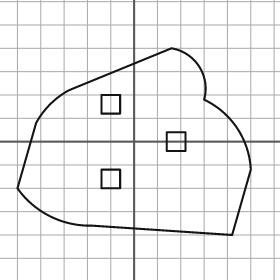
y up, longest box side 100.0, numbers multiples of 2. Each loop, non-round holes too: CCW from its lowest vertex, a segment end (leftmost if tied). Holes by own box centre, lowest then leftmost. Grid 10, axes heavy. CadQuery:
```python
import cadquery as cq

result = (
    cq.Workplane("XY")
    .moveTo(42.0, -40.0)
    .lineTo(50.0, -12.0)
    .threePointArc((44.0, 6.0), (30.0, 18.0))
    .threePointArc((28.0, 32.0), (16.0, 40.0))
    .lineTo(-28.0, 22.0)
    .threePointArc((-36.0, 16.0), (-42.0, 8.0))
    .lineTo(-50.0, -20.0)
    .threePointArc((-36.0, -32.0), (-18.0, -36.0))
    .close()
    .moveTo(-14.0, -20.0)
    .lineTo(-6.0, -20.0)
    .lineTo(-6.0, -12.0)
    .lineTo(-14.0, -12.0)
    .close()
    .moveTo(14.0, -4.0)
    .lineTo(22.0, -4.0)
    .lineTo(22.0, 4.0)
    .lineTo(14.0, 4.0)
    .close()
    .moveTo(-14.0, 12.0)
    .lineTo(-6.0, 12.0)
    .lineTo(-6.0, 20.0)
    .lineTo(-14.0, 20.0)
    .close()
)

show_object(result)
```